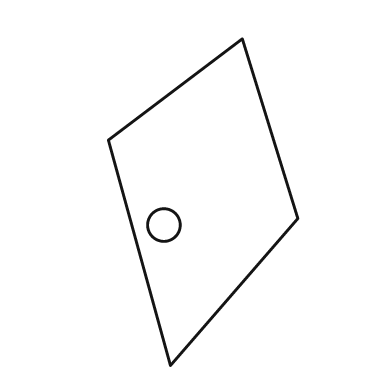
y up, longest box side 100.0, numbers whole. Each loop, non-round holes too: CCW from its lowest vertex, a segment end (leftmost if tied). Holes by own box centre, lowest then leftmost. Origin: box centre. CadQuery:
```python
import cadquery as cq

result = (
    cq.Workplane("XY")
    .moveTo(-10.0, -50.0)
    .lineTo(29.0, -5.0)
    .lineTo(12.0, 50.0)
    .lineTo(-29.0, 19.0)
    .close()
    .moveTo(-12.0, -7.0)
    .circle(5.0)
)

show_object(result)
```